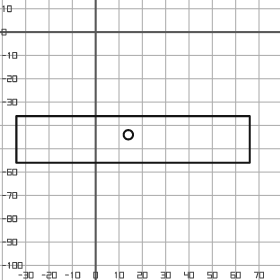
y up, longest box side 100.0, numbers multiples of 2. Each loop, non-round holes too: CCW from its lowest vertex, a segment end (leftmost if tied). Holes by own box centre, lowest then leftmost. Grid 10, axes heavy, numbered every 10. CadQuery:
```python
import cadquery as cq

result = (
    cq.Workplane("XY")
    .moveTo(-34.0, -56.0)
    .lineTo(66.0, -56.0)
    .lineTo(66.0, -36.0)
    .lineTo(-34.0, -36.0)
    .close()
    .moveTo(14.0, -44.0)
    .circle(2.0)
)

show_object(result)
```